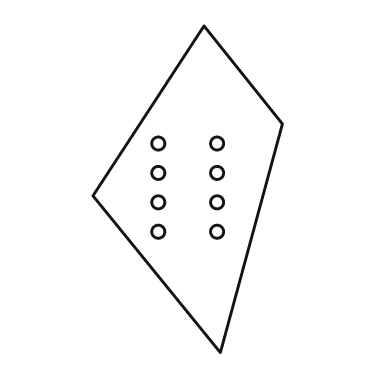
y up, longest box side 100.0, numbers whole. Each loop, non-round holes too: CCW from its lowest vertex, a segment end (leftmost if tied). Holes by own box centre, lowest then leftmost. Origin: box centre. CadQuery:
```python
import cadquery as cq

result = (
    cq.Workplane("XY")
    .moveTo(10.0, -50.0)
    .lineTo(29.0, 20.0)
    .lineTo(5.0, 50.0)
    .lineTo(-29.0, -2.0)
    .close()
    .moveTo(-9.0, -13.0)
    .circle(2.0)
    .moveTo(9.0, -13.0)
    .circle(2.0)
    .moveTo(-9.0, -4.0)
    .circle(2.0)
    .moveTo(9.0, -4.0)
    .circle(2.0)
    .moveTo(-9.0, 5.0)
    .circle(2.0)
    .moveTo(9.0, 5.0)
    .circle(2.0)
    .moveTo(-9.0, 14.0)
    .circle(2.0)
    .moveTo(9.0, 14.0)
    .circle(2.0)
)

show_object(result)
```